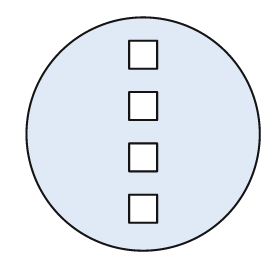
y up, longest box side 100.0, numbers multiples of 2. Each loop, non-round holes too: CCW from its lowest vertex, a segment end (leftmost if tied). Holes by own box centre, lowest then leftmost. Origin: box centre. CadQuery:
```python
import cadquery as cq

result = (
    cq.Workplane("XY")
    .moveTo(0.0, 0.0)
    .circle(50.0)
    .moveTo(-6.0, -38.0)
    .lineTo(6.0, -38.0)
    .lineTo(6.0, -26.0)
    .lineTo(-6.0, -26.0)
    .close()
    .moveTo(-6.0, -16.0)
    .lineTo(6.0, -16.0)
    .lineTo(6.0, -4.0)
    .lineTo(-6.0, -4.0)
    .close()
    .moveTo(-6.0, 6.0)
    .lineTo(6.0, 6.0)
    .lineTo(6.0, 18.0)
    .lineTo(-6.0, 18.0)
    .close()
    .moveTo(-6.0, 28.0)
    .lineTo(6.0, 28.0)
    .lineTo(6.0, 40.0)
    .lineTo(-6.0, 40.0)
    .close()
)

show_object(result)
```